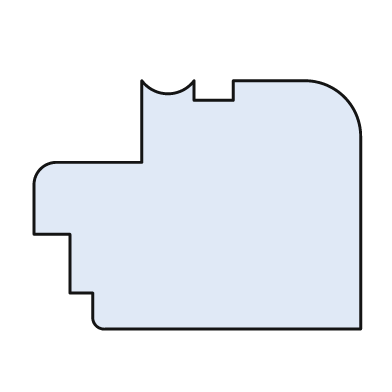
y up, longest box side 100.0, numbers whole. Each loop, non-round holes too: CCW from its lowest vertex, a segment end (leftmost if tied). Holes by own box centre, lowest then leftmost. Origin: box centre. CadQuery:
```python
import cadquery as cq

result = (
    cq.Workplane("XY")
    .moveTo(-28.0, -38.0)
    .lineTo(50.0, -38.0)
    .lineTo(50.0, 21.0)
    .threePointArc((45.0, 33.0), (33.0, 38.0))
    .lineTo(11.0, 38.0)
    .lineTo(11.0, 32.0)
    .lineTo(-1.0, 32.0)
    .lineTo(-1.0, 38.0)
    .threePointArc((-9.0, 34.0), (-17.0, 38.0))
    .lineTo(-17.0, 13.0)
    .lineTo(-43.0, 13.0)
    .threePointArc((-48.0, 11.0), (-50.0, 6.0))
    .lineTo(-50.0, -9.0)
    .lineTo(-39.0, -9.0)
    .lineTo(-39.0, -27.0)
    .lineTo(-32.0, -27.0)
    .lineTo(-32.0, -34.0)
    .threePointArc((-31.0, -37.0), (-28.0, -38.0))
    .close()
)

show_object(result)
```